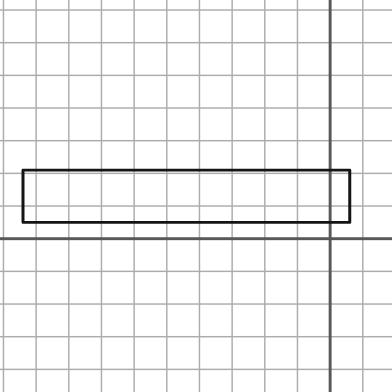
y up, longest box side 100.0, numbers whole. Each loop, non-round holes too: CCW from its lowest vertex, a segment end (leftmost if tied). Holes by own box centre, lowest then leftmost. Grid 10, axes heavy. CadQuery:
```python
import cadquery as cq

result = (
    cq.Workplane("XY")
    .moveTo(-94.0, 5.0)
    .lineTo(6.0, 5.0)
    .lineTo(6.0, 21.0)
    .lineTo(-94.0, 21.0)
    .close()
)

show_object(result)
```